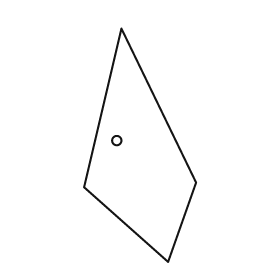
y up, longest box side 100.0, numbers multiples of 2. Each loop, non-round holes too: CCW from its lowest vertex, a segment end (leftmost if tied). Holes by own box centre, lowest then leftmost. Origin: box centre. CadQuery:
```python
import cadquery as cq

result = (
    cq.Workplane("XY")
    .moveTo(12.0, -50.0)
    .lineTo(24.0, -16.0)
    .lineTo(-8.0, 50.0)
    .lineTo(-24.0, -18.0)
    .close()
    .moveTo(-10.0, 2.0)
    .circle(2.0)
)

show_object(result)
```